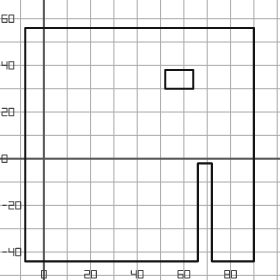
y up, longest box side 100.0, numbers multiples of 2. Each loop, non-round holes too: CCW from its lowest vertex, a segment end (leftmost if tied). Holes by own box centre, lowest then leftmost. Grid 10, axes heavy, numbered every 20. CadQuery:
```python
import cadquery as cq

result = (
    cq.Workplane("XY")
    .moveTo(-8.0, -44.0)
    .lineTo(66.0, -44.0)
    .lineTo(66.0, -2.0)
    .lineTo(72.0, -2.0)
    .lineTo(72.0, -44.0)
    .lineTo(90.0, -44.0)
    .lineTo(90.0, 56.0)
    .lineTo(-8.0, 56.0)
    .close()
    .moveTo(52.0, 30.0)
    .lineTo(64.0, 30.0)
    .lineTo(64.0, 38.0)
    .lineTo(52.0, 38.0)
    .close()
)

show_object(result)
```